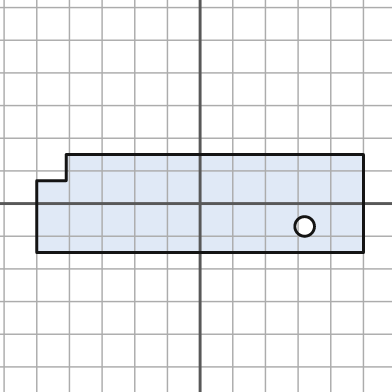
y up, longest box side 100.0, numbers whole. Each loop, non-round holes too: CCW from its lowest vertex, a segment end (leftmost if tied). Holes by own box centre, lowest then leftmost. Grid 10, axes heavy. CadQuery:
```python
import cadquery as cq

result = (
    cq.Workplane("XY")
    .moveTo(-50.0, -15.0)
    .lineTo(50.0, -15.0)
    .lineTo(50.0, 15.0)
    .lineTo(-41.0, 15.0)
    .lineTo(-41.0, 7.0)
    .lineTo(-50.0, 7.0)
    .close()
    .moveTo(32.0, -7.0)
    .circle(3.0)
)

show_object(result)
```